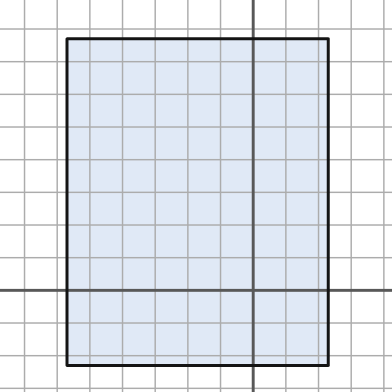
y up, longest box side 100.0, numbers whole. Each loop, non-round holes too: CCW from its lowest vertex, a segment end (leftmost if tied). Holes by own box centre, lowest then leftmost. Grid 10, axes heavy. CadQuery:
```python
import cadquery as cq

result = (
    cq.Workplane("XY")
    .moveTo(-57.0, -23.0)
    .lineTo(23.0, -23.0)
    .lineTo(23.0, 77.0)
    .lineTo(-57.0, 77.0)
    .close()
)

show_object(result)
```